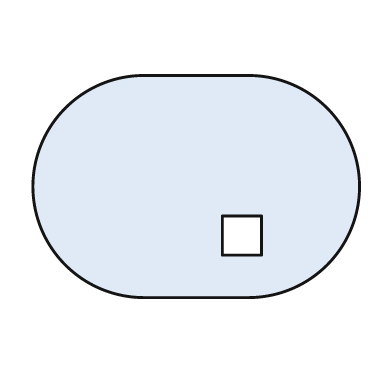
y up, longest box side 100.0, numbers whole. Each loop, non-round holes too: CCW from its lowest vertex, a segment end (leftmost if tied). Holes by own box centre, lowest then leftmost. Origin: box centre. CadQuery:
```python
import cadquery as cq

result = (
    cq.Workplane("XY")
    .moveTo(-16.0, -34.0)
    .lineTo(16.0, -34.0)
    .threePointArc((50.0, 0.0), (16.0, 34.0))
    .lineTo(-16.0, 34.0)
    .threePointArc((-50.0, 0.0), (-16.0, -34.0))
    .close()
    .moveTo(8.0, -21.0)
    .lineTo(20.0, -21.0)
    .lineTo(20.0, -9.0)
    .lineTo(8.0, -9.0)
    .close()
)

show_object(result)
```